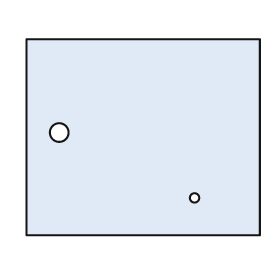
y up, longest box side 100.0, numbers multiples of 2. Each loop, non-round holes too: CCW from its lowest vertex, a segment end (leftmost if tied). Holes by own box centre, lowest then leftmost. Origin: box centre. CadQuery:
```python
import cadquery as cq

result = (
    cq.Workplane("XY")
    .moveTo(-50.0, -42.0)
    .lineTo(50.0, -42.0)
    .lineTo(50.0, 42.0)
    .lineTo(-50.0, 42.0)
    .close()
    .moveTo(22.0, -26.0)
    .circle(2.0)
    .moveTo(-36.0, 2.0)
    .circle(4.0)
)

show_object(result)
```